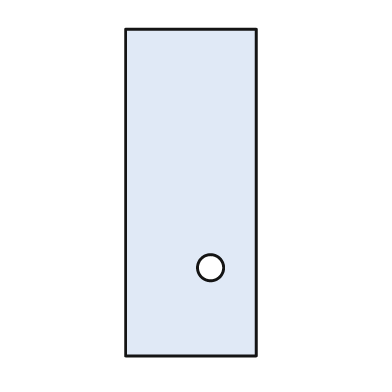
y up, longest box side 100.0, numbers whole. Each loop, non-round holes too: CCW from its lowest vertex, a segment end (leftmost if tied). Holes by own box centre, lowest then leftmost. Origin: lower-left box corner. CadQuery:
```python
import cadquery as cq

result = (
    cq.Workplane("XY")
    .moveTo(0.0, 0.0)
    .lineTo(40.0, 0.0)
    .lineTo(40.0, 100.0)
    .lineTo(0.0, 100.0)
    .close()
    .moveTo(26.0, 27.0)
    .circle(4.0)
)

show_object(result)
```